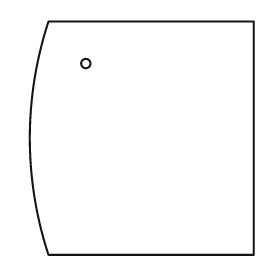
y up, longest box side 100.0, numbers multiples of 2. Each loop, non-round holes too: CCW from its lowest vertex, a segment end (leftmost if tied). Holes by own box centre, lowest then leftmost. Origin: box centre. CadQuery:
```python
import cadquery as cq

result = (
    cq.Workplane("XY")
    .moveTo(-40.0, -50.0)
    .lineTo(48.0, -50.0)
    .lineTo(48.0, 50.0)
    .lineTo(-40.0, 50.0)
    .threePointArc((-48.0, 0.0), (-40.0, -50.0))
    .close()
    .moveTo(-24.0, 32.0)
    .circle(2.0)
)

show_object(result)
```